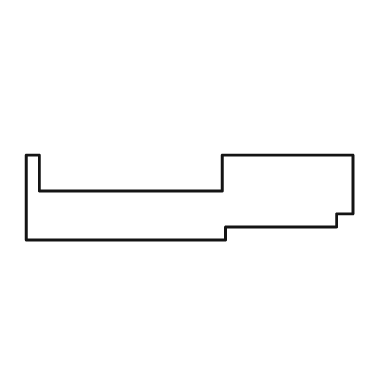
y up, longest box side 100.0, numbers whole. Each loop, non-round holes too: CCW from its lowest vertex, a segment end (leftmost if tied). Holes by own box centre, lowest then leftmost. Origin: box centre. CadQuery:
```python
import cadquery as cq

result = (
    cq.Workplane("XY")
    .moveTo(-50.0, -13.0)
    .lineTo(11.0, -13.0)
    .lineTo(11.0, -9.0)
    .lineTo(45.0, -9.0)
    .lineTo(45.0, -5.0)
    .lineTo(50.0, -5.0)
    .lineTo(50.0, 13.0)
    .lineTo(10.0, 13.0)
    .lineTo(10.0, 2.0)
    .lineTo(-46.0, 2.0)
    .lineTo(-46.0, 13.0)
    .lineTo(-50.0, 13.0)
    .close()
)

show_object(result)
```